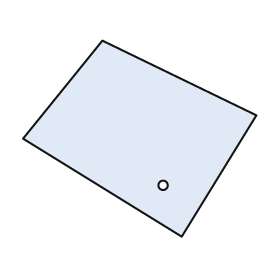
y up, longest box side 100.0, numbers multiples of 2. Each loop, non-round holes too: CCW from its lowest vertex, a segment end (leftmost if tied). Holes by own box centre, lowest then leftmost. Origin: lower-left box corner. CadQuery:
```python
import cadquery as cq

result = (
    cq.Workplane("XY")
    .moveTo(68.0, 0.0)
    .lineTo(100.0, 52.0)
    .lineTo(34.0, 84.0)
    .lineTo(0.0, 42.0)
    .close()
    .moveTo(60.0, 22.0)
    .circle(2.0)
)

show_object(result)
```